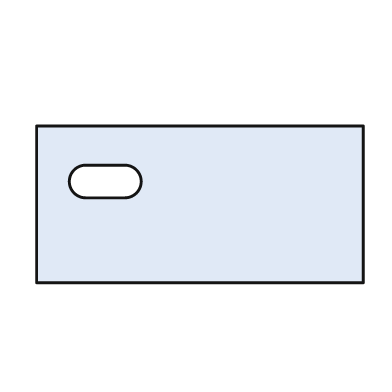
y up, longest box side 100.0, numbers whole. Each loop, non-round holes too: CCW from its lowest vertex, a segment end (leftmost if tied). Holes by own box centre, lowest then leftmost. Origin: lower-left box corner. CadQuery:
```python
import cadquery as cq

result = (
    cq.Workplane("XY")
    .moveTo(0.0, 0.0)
    .lineTo(100.0, 0.0)
    .lineTo(100.0, 48.0)
    .lineTo(0.0, 48.0)
    .close()
    .moveTo(15.0, 26.0)
    .lineTo(27.0, 26.0)
    .threePointArc((32.0, 31.0), (27.0, 36.0))
    .lineTo(15.0, 36.0)
    .threePointArc((10.0, 31.0), (15.0, 26.0))
    .close()
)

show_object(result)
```